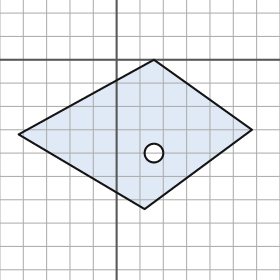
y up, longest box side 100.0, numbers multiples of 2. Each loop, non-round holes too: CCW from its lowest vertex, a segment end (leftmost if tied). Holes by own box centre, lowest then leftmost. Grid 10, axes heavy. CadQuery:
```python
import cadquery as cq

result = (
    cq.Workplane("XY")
    .moveTo(12.0, -64.0)
    .lineTo(58.0, -30.0)
    .lineTo(16.0, 0.0)
    .lineTo(-42.0, -32.0)
    .close()
    .moveTo(16.0, -40.0)
    .circle(4.0)
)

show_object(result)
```